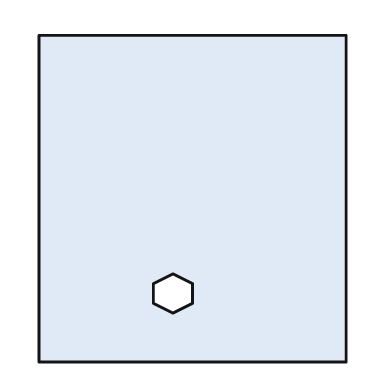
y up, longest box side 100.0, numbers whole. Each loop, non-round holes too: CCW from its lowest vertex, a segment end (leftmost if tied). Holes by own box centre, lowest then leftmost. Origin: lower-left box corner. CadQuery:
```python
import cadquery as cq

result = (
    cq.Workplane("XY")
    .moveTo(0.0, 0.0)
    .lineTo(94.0, 0.0)
    .lineTo(94.0, 100.0)
    .lineTo(0.0, 100.0)
    .close()
    .moveTo(41.0, 15.0)
    .lineTo(47.0, 18.0)
    .lineTo(47.0, 24.0)
    .lineTo(41.0, 27.0)
    .lineTo(35.0, 24.0)
    .lineTo(35.0, 18.0)
    .close()
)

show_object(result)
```